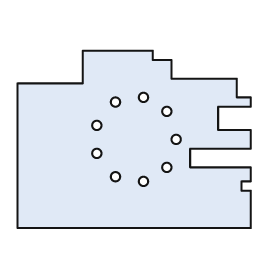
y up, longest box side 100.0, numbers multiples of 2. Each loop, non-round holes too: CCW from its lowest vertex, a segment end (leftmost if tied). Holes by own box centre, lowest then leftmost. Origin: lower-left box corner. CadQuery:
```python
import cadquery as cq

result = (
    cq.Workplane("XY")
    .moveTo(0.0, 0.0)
    .lineTo(100.0, 0.0)
    .lineTo(100.0, 16.0)
    .lineTo(96.0, 16.0)
    .lineTo(96.0, 20.0)
    .lineTo(100.0, 20.0)
    .lineTo(100.0, 26.0)
    .lineTo(74.0, 26.0)
    .lineTo(74.0, 34.0)
    .lineTo(100.0, 34.0)
    .lineTo(100.0, 42.0)
    .lineTo(86.0, 42.0)
    .lineTo(86.0, 52.0)
    .lineTo(100.0, 52.0)
    .lineTo(100.0, 56.0)
    .lineTo(94.0, 56.0)
    .lineTo(94.0, 64.0)
    .lineTo(66.0, 64.0)
    .lineTo(66.0, 72.0)
    .lineTo(58.0, 72.0)
    .lineTo(58.0, 76.0)
    .lineTo(28.0, 76.0)
    .lineTo(28.0, 62.0)
    .lineTo(0.0, 62.0)
    .close()
    .moveTo(54.0, 20.0)
    .circle(2.0)
    .moveTo(42.0, 22.0)
    .circle(2.0)
    .moveTo(64.0, 26.0)
    .circle(2.0)
    .moveTo(34.0, 32.0)
    .circle(2.0)
    .moveTo(68.0, 38.0)
    .circle(2.0)
    .moveTo(34.0, 44.0)
    .circle(2.0)
    .moveTo(64.0, 50.0)
    .circle(2.0)
    .moveTo(42.0, 54.0)
    .circle(2.0)
    .moveTo(54.0, 56.0)
    .circle(2.0)
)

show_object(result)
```